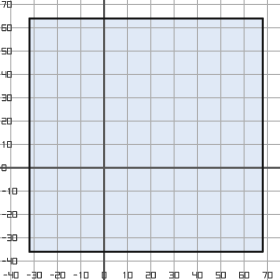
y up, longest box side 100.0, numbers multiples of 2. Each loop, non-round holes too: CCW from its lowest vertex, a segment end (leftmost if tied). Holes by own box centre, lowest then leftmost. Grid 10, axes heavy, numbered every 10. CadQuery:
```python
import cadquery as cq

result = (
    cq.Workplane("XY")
    .moveTo(-32.0, -36.0)
    .lineTo(68.0, -36.0)
    .lineTo(68.0, 64.0)
    .lineTo(-32.0, 64.0)
    .close()
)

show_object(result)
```